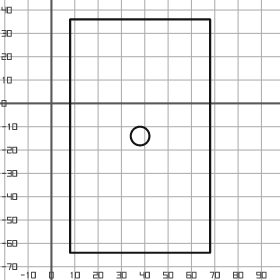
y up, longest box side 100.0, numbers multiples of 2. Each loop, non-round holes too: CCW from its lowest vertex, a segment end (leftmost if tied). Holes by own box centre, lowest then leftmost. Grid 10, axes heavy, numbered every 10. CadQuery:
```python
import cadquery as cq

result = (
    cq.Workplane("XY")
    .moveTo(8.0, -64.0)
    .lineTo(68.0, -64.0)
    .lineTo(68.0, 36.0)
    .lineTo(8.0, 36.0)
    .close()
    .moveTo(38.0, -14.0)
    .circle(4.0)
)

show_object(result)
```